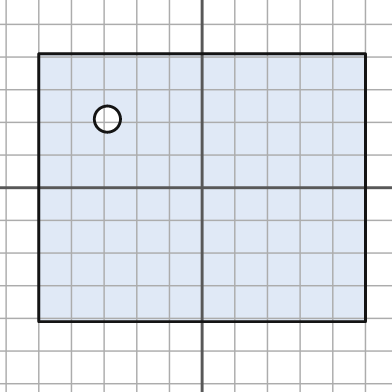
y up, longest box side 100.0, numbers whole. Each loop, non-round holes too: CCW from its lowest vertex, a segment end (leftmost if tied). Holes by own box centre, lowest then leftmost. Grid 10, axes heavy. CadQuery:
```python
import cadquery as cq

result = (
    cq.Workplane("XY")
    .moveTo(-50.0, -41.0)
    .lineTo(50.0, -41.0)
    .lineTo(50.0, 41.0)
    .lineTo(-50.0, 41.0)
    .close()
    .moveTo(-29.0, 21.0)
    .circle(4.0)
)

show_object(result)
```